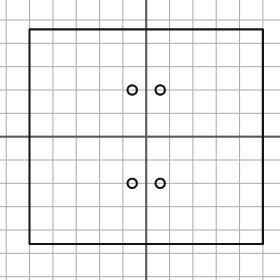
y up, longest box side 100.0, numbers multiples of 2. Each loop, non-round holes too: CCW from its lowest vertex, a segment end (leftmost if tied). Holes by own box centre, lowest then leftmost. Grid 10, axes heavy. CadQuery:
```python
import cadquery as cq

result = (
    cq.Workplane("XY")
    .moveTo(-50.0, -46.0)
    .lineTo(50.0, -46.0)
    .lineTo(50.0, 46.0)
    .lineTo(-50.0, 46.0)
    .close()
    .moveTo(-6.0, -20.0)
    .circle(2.0)
    .moveTo(6.0, -20.0)
    .circle(2.0)
    .moveTo(-6.0, 20.0)
    .circle(2.0)
    .moveTo(6.0, 20.0)
    .circle(2.0)
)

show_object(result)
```